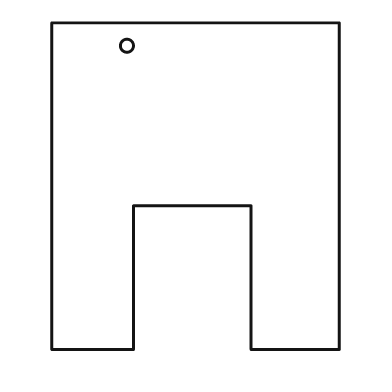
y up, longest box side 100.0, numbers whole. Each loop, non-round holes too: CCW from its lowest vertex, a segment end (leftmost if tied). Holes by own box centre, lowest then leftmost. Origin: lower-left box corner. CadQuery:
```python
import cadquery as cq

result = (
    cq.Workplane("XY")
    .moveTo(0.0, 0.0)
    .lineTo(25.0, 0.0)
    .lineTo(25.0, 44.0)
    .lineTo(61.0, 44.0)
    .lineTo(61.0, 0.0)
    .lineTo(88.0, 0.0)
    .lineTo(88.0, 100.0)
    .lineTo(0.0, 100.0)
    .close()
    .moveTo(23.0, 93.0)
    .circle(2.0)
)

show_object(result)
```